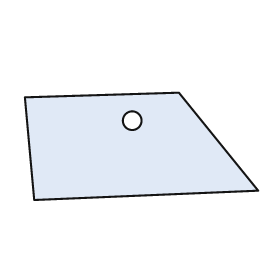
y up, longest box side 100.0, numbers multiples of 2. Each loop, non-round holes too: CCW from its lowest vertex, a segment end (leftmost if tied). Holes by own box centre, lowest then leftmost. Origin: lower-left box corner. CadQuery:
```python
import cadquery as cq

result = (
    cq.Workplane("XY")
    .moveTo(4.0, 0.0)
    .lineTo(100.0, 4.0)
    .lineTo(66.0, 46.0)
    .lineTo(0.0, 44.0)
    .close()
    .moveTo(46.0, 34.0)
    .circle(4.0)
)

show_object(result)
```